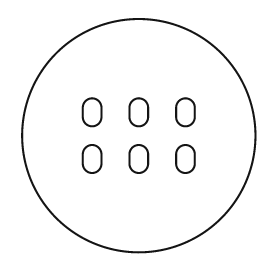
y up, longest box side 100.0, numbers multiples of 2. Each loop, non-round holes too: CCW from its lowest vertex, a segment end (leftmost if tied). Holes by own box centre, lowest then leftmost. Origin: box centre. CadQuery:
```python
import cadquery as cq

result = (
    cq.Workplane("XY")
    .moveTo(0.0, 0.0)
    .circle(50.0)
    .moveTo(-24.0, -12.0)
    .threePointArc((-20.0, -16.0), (-16.0, -12.0))
    .lineTo(-16.0, -8.0)
    .threePointArc((-20.0, -4.0), (-24.0, -8.0))
    .close()
    .moveTo(-4.0, -12.0)
    .threePointArc((0.0, -16.0), (4.0, -12.0))
    .lineTo(4.0, -8.0)
    .threePointArc((0.0, -4.0), (-4.0, -8.0))
    .close()
    .moveTo(16.0, -12.0)
    .threePointArc((20.0, -16.0), (24.0, -12.0))
    .lineTo(24.0, -8.0)
    .threePointArc((20.0, -4.0), (16.0, -8.0))
    .close()
    .moveTo(-24.0, 8.0)
    .threePointArc((-20.0, 4.0), (-16.0, 8.0))
    .lineTo(-16.0, 12.0)
    .threePointArc((-20.0, 16.0), (-24.0, 12.0))
    .close()
    .moveTo(-4.0, 8.0)
    .threePointArc((0.0, 4.0), (4.0, 8.0))
    .lineTo(4.0, 12.0)
    .threePointArc((0.0, 16.0), (-4.0, 12.0))
    .close()
    .moveTo(16.0, 8.0)
    .threePointArc((20.0, 4.0), (24.0, 8.0))
    .lineTo(24.0, 12.0)
    .threePointArc((20.0, 16.0), (16.0, 12.0))
    .close()
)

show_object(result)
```